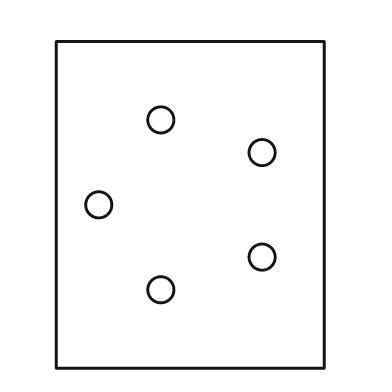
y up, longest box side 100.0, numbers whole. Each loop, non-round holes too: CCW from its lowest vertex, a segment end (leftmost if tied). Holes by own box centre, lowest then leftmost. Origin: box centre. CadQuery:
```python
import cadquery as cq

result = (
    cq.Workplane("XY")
    .moveTo(-41.0, -50.0)
    .lineTo(41.0, -50.0)
    .lineTo(41.0, 50.0)
    .lineTo(-41.0, 50.0)
    .close()
    .moveTo(-9.0, -26.0)
    .circle(4.0)
    .moveTo(22.0, -16.0)
    .circle(4.0)
    .moveTo(-28.0, 0.0)
    .circle(4.0)
    .moveTo(22.0, 16.0)
    .circle(4.0)
    .moveTo(-9.0, 26.0)
    .circle(4.0)
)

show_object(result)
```